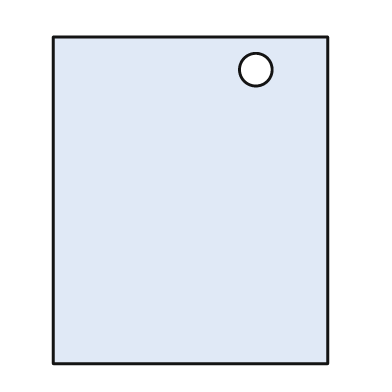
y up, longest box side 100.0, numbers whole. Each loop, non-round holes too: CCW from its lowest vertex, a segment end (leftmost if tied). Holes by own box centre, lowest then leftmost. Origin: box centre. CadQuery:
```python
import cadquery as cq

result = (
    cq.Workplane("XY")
    .moveTo(-42.0, -50.0)
    .lineTo(42.0, -50.0)
    .lineTo(42.0, 50.0)
    .lineTo(-42.0, 50.0)
    .close()
    .moveTo(20.0, 40.0)
    .circle(5.0)
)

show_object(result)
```